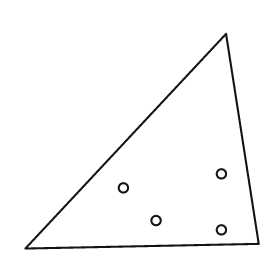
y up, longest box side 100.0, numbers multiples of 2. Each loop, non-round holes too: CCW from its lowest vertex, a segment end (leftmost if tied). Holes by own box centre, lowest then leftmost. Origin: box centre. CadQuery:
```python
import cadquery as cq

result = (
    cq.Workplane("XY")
    .moveTo(-50.0, -46.0)
    .lineTo(50.0, -44.0)
    .lineTo(36.0, 46.0)
    .close()
    .moveTo(34.0, -38.0)
    .circle(2.0)
    .moveTo(6.0, -34.0)
    .circle(2.0)
    .moveTo(-8.0, -20.0)
    .circle(2.0)
    .moveTo(34.0, -14.0)
    .circle(2.0)
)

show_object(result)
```